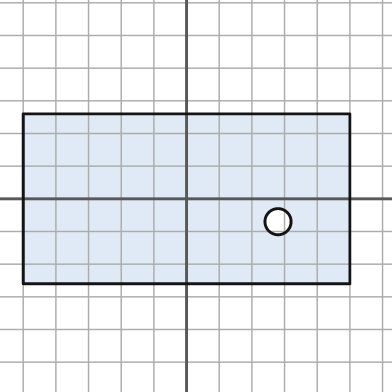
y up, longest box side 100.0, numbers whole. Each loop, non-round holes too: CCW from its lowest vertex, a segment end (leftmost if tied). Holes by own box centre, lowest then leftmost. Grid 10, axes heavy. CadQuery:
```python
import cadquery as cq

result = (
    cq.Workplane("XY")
    .moveTo(-50.0, -26.0)
    .lineTo(50.0, -26.0)
    .lineTo(50.0, 26.0)
    .lineTo(-50.0, 26.0)
    .close()
    .moveTo(28.0, -7.0)
    .circle(4.0)
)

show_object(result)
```